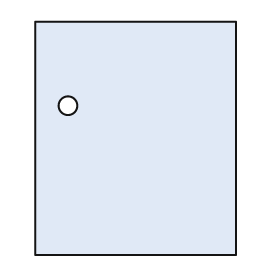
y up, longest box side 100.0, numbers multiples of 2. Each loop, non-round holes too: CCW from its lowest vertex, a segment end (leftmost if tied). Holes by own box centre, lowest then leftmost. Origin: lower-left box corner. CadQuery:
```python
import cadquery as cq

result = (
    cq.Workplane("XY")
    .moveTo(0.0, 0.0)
    .lineTo(86.0, 0.0)
    .lineTo(86.0, 100.0)
    .lineTo(0.0, 100.0)
    .close()
    .moveTo(14.0, 64.0)
    .circle(4.0)
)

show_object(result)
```